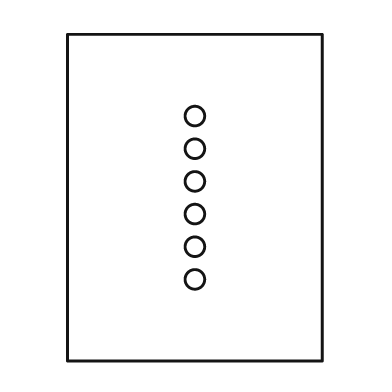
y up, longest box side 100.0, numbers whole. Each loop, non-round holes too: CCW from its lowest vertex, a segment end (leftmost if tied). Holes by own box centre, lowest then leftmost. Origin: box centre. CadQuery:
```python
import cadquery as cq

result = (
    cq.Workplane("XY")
    .moveTo(-39.0, -50.0)
    .lineTo(39.0, -50.0)
    .lineTo(39.0, 50.0)
    .lineTo(-39.0, 50.0)
    .close()
    .moveTo(0.0, -25.0)
    .circle(3.0)
    .moveTo(0.0, -15.0)
    .circle(3.0)
    .moveTo(0.0, -5.0)
    .circle(3.0)
    .moveTo(0.0, 5.0)
    .circle(3.0)
    .moveTo(0.0, 15.0)
    .circle(3.0)
    .moveTo(0.0, 25.0)
    .circle(3.0)
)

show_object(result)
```